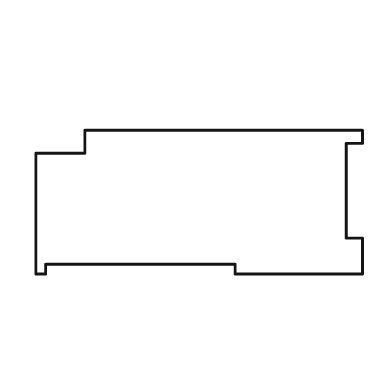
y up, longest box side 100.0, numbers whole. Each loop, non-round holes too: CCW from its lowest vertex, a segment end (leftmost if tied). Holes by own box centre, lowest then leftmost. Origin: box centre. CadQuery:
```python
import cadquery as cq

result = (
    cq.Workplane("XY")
    .moveTo(-50.0, -22.0)
    .lineTo(-47.0, -22.0)
    .lineTo(-47.0, -19.0)
    .lineTo(11.0, -19.0)
    .lineTo(11.0, -22.0)
    .lineTo(50.0, -22.0)
    .lineTo(50.0, -11.0)
    .lineTo(45.0, -11.0)
    .lineTo(45.0, 18.0)
    .lineTo(50.0, 18.0)
    .lineTo(50.0, 22.0)
    .lineTo(-35.0, 22.0)
    .lineTo(-35.0, 15.0)
    .lineTo(-50.0, 15.0)
    .close()
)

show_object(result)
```